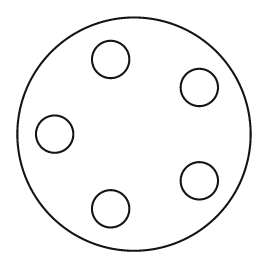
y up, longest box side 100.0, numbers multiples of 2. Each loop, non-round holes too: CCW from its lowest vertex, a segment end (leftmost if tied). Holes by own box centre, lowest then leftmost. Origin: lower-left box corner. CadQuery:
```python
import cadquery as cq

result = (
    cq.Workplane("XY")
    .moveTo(50.0, 50.0)
    .circle(50.0)
    .moveTo(40.0, 18.0)
    .circle(8.0)
    .moveTo(78.0, 30.0)
    .circle(8.0)
    .moveTo(16.0, 50.0)
    .circle(8.0)
    .moveTo(78.0, 70.0)
    .circle(8.0)
    .moveTo(40.0, 82.0)
    .circle(8.0)
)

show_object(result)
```